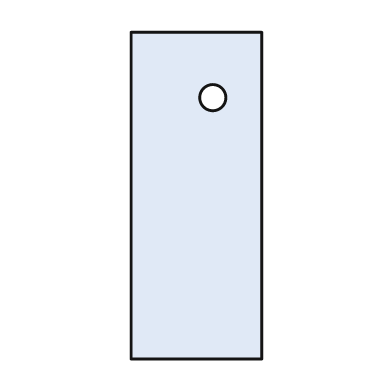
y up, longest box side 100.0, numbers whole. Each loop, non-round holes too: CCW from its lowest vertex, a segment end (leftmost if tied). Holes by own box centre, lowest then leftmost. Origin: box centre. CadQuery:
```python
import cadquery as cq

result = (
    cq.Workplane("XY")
    .moveTo(-20.0, -50.0)
    .lineTo(20.0, -50.0)
    .lineTo(20.0, 50.0)
    .lineTo(-20.0, 50.0)
    .close()
    .moveTo(5.0, 30.0)
    .circle(4.0)
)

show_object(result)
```